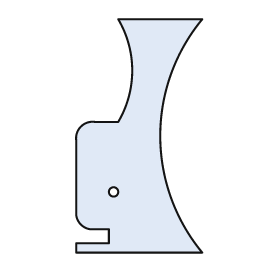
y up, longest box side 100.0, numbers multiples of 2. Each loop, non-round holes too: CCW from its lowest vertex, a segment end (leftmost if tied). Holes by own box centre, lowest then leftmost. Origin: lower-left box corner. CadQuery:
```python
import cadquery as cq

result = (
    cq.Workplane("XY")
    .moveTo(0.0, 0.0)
    .lineTo(54.0, 0.0)
    .threePointArc((36.0, 50.0), (54.0, 100.0))
    .lineTo(18.0, 100.0)
    .threePointArc((24.0, 78.0), (18.0, 56.0))
    .lineTo(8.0, 56.0)
    .threePointArc((2.0, 54.0), (0.0, 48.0))
    .lineTo(0.0, 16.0)
    .threePointArc((2.0, 12.0), (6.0, 10.0))
    .lineTo(14.0, 10.0)
    .lineTo(14.0, 4.0)
    .lineTo(0.0, 4.0)
    .close()
    .moveTo(16.0, 26.0)
    .circle(2.0)
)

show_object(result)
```